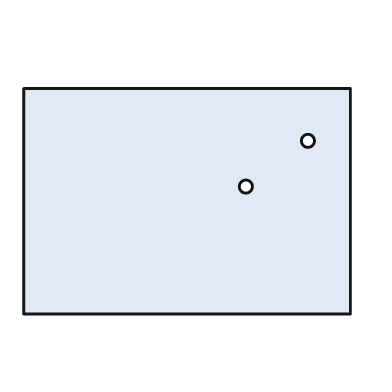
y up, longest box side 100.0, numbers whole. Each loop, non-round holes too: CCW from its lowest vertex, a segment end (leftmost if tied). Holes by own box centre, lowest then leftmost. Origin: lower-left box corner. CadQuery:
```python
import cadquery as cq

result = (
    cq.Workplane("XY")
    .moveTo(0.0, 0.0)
    .lineTo(100.0, 0.0)
    .lineTo(100.0, 69.0)
    .lineTo(0.0, 69.0)
    .close()
    .moveTo(68.0, 39.0)
    .circle(2.0)
    .moveTo(87.0, 53.0)
    .circle(2.0)
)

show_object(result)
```